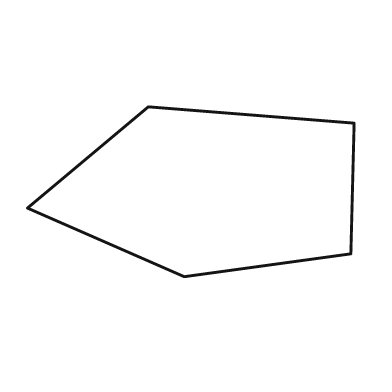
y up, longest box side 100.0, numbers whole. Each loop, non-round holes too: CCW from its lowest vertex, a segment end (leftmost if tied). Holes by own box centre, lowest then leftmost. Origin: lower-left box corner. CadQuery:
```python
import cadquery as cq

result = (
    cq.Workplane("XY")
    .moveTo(48.0, 0.0)
    .lineTo(99.0, 7.0)
    .lineTo(100.0, 47.0)
    .lineTo(37.0, 52.0)
    .lineTo(0.0, 21.0)
    .close()
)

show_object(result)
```